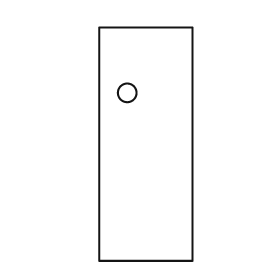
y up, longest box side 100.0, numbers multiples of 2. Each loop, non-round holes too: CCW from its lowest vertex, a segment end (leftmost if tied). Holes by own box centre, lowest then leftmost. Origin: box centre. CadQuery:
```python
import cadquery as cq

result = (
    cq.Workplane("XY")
    .moveTo(-20.0, -50.0)
    .lineTo(20.0, -50.0)
    .lineTo(20.0, 50.0)
    .lineTo(-20.0, 50.0)
    .close()
    .moveTo(-8.0, 22.0)
    .circle(4.0)
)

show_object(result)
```